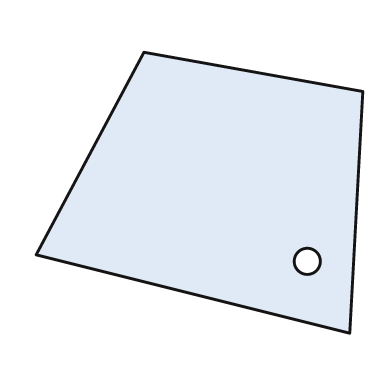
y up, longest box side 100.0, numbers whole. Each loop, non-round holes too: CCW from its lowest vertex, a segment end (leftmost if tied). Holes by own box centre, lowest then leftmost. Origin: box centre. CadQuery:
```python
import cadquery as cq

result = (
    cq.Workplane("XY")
    .moveTo(46.0, -43.0)
    .lineTo(50.0, 31.0)
    .lineTo(-17.0, 43.0)
    .lineTo(-50.0, -19.0)
    .close()
    .moveTo(33.0, -21.0)
    .circle(4.0)
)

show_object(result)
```